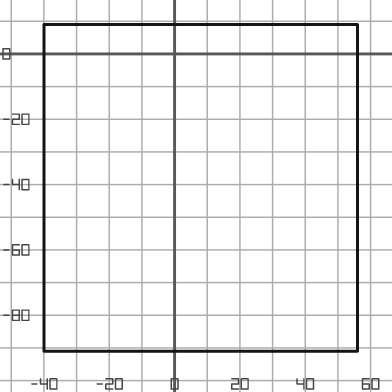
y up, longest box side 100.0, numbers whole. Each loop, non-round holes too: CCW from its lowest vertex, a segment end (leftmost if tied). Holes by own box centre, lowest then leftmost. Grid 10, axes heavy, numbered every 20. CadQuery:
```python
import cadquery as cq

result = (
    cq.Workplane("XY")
    .moveTo(-40.0, -91.0)
    .lineTo(56.0, -91.0)
    .lineTo(56.0, 9.0)
    .lineTo(-40.0, 9.0)
    .close()
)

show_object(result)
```